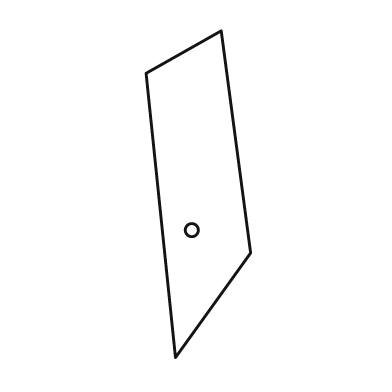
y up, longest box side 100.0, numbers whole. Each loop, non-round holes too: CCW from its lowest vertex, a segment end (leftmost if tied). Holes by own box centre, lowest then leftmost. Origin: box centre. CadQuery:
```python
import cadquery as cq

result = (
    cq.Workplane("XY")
    .moveTo(-7.0, -50.0)
    .lineTo(16.0, -18.0)
    .lineTo(7.0, 50.0)
    .lineTo(-16.0, 37.0)
    .close()
    .moveTo(-2.0, -11.0)
    .circle(2.0)
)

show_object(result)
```